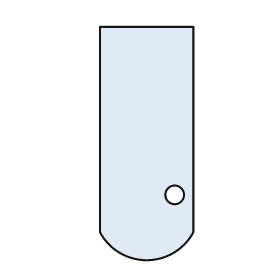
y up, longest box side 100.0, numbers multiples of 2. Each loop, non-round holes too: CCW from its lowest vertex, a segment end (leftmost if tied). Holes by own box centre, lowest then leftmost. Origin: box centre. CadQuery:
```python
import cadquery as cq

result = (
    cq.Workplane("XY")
    .moveTo(-20.0, -38.0)
    .threePointArc((0.0, -50.0), (20.0, -38.0))
    .lineTo(20.0, 50.0)
    .lineTo(-20.0, 50.0)
    .close()
    .moveTo(12.0, -22.0)
    .circle(4.0)
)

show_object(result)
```